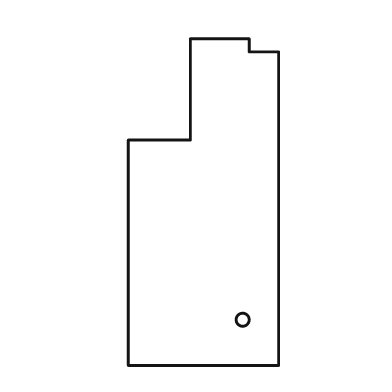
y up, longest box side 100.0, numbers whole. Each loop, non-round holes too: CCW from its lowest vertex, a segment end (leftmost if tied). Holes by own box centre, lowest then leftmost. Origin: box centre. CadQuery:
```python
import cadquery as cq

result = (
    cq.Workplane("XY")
    .moveTo(-23.0, -50.0)
    .lineTo(23.0, -50.0)
    .lineTo(23.0, 46.0)
    .lineTo(14.0, 46.0)
    .lineTo(14.0, 50.0)
    .lineTo(-4.0, 50.0)
    .lineTo(-4.0, 19.0)
    .lineTo(-23.0, 19.0)
    .close()
    .moveTo(12.0, -36.0)
    .circle(2.0)
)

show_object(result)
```